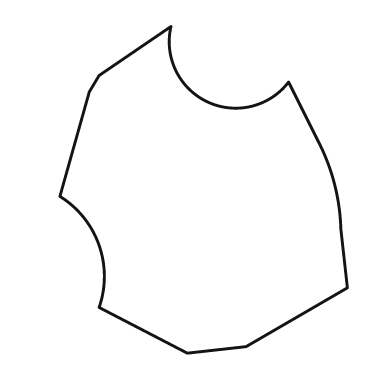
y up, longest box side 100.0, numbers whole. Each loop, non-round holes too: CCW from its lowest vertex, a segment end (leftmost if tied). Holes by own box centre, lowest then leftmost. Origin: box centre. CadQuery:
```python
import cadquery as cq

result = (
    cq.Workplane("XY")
    .moveTo(-5.0, -50.0)
    .lineTo(13.0, -48.0)
    .lineTo(44.0, -30.0)
    .lineTo(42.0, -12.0)
    .threePointArc((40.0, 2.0), (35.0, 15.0))
    .lineTo(26.0, 33.0)
    .threePointArc((1.0, 27.0), (-10.0, 50.0))
    .lineTo(-32.0, 35.0)
    .lineTo(-35.0, 30.0)
    .lineTo(-44.0, -2.0)
    .threePointArc((-32.0, -17.0), (-32.0, -36.0))
    .close()
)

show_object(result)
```